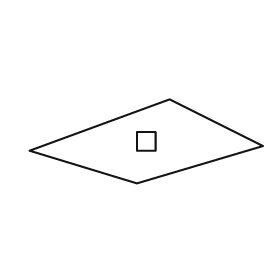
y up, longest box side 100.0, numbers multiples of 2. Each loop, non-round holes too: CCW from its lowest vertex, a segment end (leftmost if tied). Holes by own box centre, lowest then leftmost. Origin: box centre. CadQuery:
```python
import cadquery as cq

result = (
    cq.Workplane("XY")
    .moveTo(-4.0, -18.0)
    .lineTo(50.0, -2.0)
    .lineTo(10.0, 18.0)
    .lineTo(-50.0, -4.0)
    .close()
    .moveTo(-4.0, -4.0)
    .lineTo(4.0, -4.0)
    .lineTo(4.0, 4.0)
    .lineTo(-4.0, 4.0)
    .close()
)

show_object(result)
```